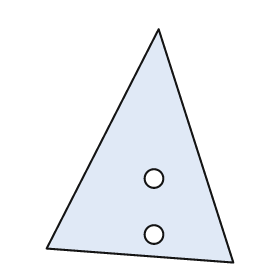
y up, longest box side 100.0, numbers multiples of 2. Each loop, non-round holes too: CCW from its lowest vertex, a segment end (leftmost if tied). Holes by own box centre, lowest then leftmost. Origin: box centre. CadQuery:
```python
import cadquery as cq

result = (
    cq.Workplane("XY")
    .moveTo(40.0, -50.0)
    .lineTo(8.0, 50.0)
    .lineTo(-40.0, -44.0)
    .close()
    .moveTo(6.0, -38.0)
    .circle(4.0)
    .moveTo(6.0, -14.0)
    .circle(4.0)
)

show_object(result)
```